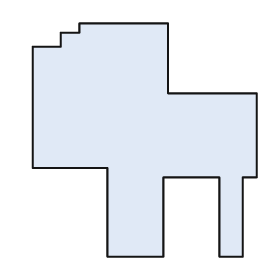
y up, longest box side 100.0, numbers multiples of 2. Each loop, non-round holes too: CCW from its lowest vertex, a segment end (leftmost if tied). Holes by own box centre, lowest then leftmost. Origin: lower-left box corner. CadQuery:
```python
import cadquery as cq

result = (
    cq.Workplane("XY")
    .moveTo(32.0, 0.0)
    .lineTo(56.0, 0.0)
    .lineTo(56.0, 34.0)
    .lineTo(80.0, 34.0)
    .lineTo(80.0, 0.0)
    .lineTo(90.0, 0.0)
    .lineTo(90.0, 34.0)
    .lineTo(96.0, 34.0)
    .lineTo(96.0, 70.0)
    .lineTo(58.0, 70.0)
    .lineTo(58.0, 100.0)
    .lineTo(20.0, 100.0)
    .lineTo(20.0, 96.0)
    .lineTo(12.0, 96.0)
    .lineTo(12.0, 90.0)
    .lineTo(0.0, 90.0)
    .lineTo(0.0, 38.0)
    .lineTo(32.0, 38.0)
    .close()
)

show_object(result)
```